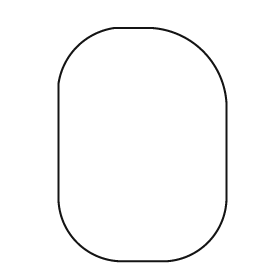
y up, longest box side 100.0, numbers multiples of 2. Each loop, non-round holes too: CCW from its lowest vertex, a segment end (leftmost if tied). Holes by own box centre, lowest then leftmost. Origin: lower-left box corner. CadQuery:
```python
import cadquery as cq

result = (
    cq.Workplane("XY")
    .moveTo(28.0, 0.0)
    .lineTo(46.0, 0.0)
    .threePointArc((64.0, 8.0), (72.0, 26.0))
    .lineTo(72.0, 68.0)
    .threePointArc((62.0, 90.0), (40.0, 100.0))
    .lineTo(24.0, 100.0)
    .threePointArc((8.0, 92.0), (0.0, 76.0))
    .lineTo(0.0, 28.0)
    .threePointArc((8.0, 8.0), (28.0, 0.0))
    .close()
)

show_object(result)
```